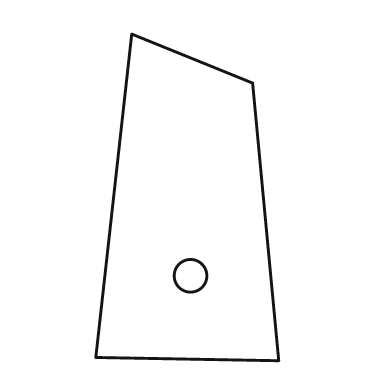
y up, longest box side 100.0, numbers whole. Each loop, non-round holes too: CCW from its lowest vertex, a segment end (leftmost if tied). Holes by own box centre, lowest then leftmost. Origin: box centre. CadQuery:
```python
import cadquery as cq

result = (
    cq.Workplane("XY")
    .moveTo(28.0, -50.0)
    .lineTo(20.0, 35.0)
    .lineTo(-17.0, 50.0)
    .lineTo(-28.0, -49.0)
    .close()
    .moveTo(1.0, -24.0)
    .circle(5.0)
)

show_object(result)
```